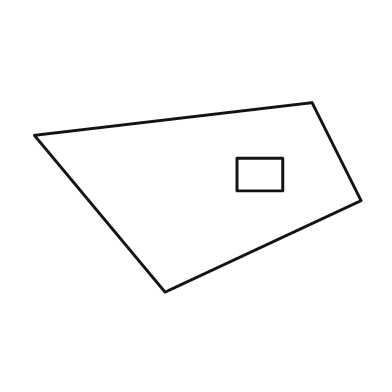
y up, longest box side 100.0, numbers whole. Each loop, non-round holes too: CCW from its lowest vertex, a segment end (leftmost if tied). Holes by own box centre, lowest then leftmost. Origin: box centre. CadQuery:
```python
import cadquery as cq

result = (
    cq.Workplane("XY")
    .moveTo(-10.0, -29.0)
    .lineTo(50.0, -1.0)
    .lineTo(35.0, 29.0)
    .lineTo(-50.0, 19.0)
    .close()
    .moveTo(12.0, 2.0)
    .lineTo(26.0, 2.0)
    .lineTo(26.0, 12.0)
    .lineTo(12.0, 12.0)
    .close()
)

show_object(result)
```